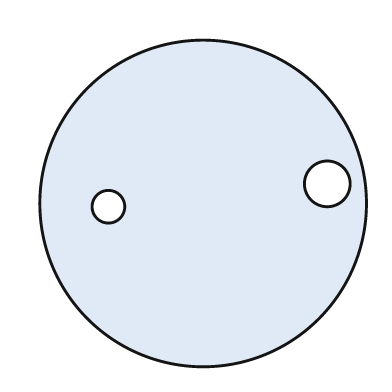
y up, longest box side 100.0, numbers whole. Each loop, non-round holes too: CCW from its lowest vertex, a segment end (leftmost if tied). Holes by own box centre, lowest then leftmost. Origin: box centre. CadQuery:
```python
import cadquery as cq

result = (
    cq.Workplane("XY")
    .moveTo(0.0, 0.0)
    .circle(50.0)
    .moveTo(-29.0, -1.0)
    .circle(5.0)
    .moveTo(38.0, 6.0)
    .circle(7.0)
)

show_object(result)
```